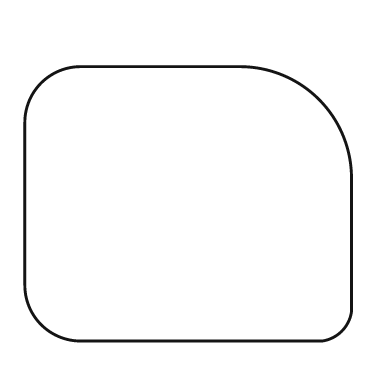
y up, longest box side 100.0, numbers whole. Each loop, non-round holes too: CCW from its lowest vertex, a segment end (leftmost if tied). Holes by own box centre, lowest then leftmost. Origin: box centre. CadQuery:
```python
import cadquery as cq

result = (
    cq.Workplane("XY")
    .moveTo(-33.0, -42.0)
    .lineTo(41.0, -42.0)
    .threePointArc((47.0, -39.0), (50.0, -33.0))
    .lineTo(50.0, 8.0)
    .threePointArc((40.0, 32.0), (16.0, 42.0))
    .lineTo(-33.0, 42.0)
    .threePointArc((-45.0, 37.0), (-50.0, 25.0))
    .lineTo(-50.0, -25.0)
    .threePointArc((-45.0, -37.0), (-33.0, -42.0))
    .close()
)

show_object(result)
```